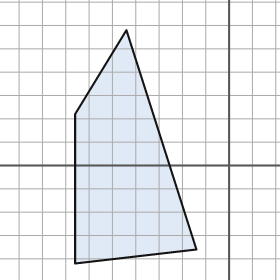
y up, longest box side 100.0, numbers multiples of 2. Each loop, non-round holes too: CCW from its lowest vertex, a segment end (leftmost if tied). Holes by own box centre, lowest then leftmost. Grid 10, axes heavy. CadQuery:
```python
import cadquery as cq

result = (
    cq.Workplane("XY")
    .moveTo(-66.0, -42.0)
    .lineTo(-14.0, -36.0)
    .lineTo(-44.0, 58.0)
    .lineTo(-66.0, 22.0)
    .close()
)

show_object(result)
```